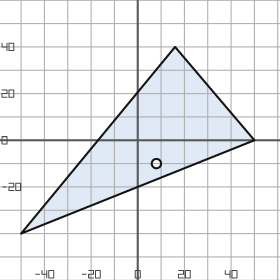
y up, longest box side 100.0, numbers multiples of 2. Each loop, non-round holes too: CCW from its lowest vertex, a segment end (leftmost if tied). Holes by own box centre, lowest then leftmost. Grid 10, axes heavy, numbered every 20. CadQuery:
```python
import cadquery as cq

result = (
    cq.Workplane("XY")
    .moveTo(-50.0, -40.0)
    .lineTo(50.0, 0.0)
    .lineTo(16.0, 40.0)
    .close()
    .moveTo(8.0, -10.0)
    .circle(2.0)
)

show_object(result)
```